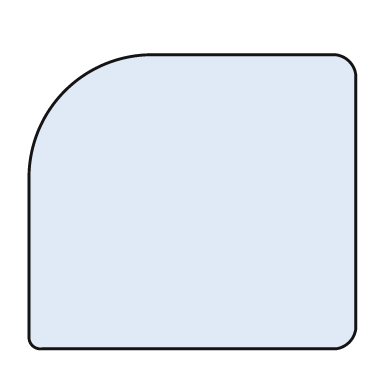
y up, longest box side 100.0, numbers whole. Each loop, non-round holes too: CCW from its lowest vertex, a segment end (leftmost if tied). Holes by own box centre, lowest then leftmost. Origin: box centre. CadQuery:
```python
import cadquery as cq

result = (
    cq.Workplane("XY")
    .moveTo(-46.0, -45.0)
    .lineTo(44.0, -45.0)
    .threePointArc((48.0, -43.0), (50.0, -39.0))
    .lineTo(50.0, 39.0)
    .threePointArc((48.0, 43.0), (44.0, 45.0))
    .lineTo(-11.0, 45.0)
    .threePointArc((-39.0, 34.0), (-50.0, 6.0))
    .lineTo(-50.0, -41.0)
    .threePointArc((-49.0, -44.0), (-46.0, -45.0))
    .close()
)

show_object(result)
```